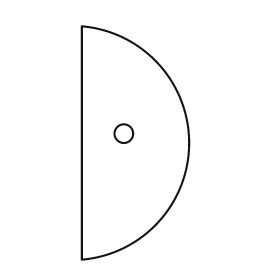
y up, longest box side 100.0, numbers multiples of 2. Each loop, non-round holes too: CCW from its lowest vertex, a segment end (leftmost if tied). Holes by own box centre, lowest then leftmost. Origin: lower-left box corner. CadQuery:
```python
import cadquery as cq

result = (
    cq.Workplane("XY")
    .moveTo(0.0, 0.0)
    .threePointArc((46.0, 50.0), (0.0, 100.0))
    .close()
    .moveTo(18.0, 54.0)
    .circle(4.0)
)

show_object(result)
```